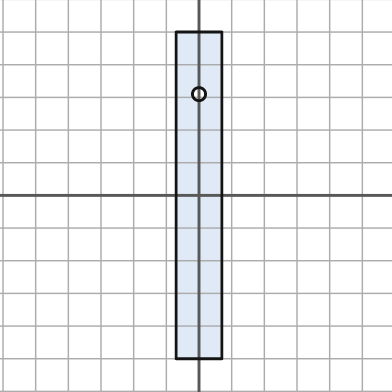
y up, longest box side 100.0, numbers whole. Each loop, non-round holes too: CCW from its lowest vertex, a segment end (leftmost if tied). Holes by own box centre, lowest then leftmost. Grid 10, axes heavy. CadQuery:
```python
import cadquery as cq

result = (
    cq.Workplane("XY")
    .moveTo(-7.0, -50.0)
    .lineTo(7.0, -50.0)
    .lineTo(7.0, 50.0)
    .lineTo(-7.0, 50.0)
    .close()
    .moveTo(0.0, 31.0)
    .circle(2.0)
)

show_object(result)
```